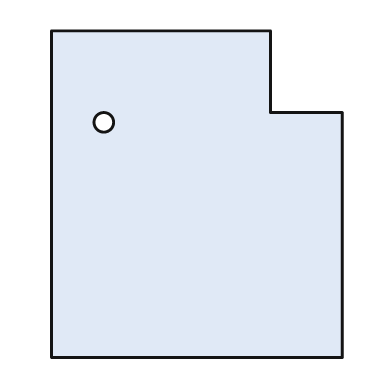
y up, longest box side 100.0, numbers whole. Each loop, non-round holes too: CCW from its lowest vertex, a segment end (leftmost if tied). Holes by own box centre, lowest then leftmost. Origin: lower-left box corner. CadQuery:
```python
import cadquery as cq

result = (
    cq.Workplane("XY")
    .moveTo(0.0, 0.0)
    .lineTo(89.0, 0.0)
    .lineTo(89.0, 75.0)
    .lineTo(67.0, 75.0)
    .lineTo(67.0, 100.0)
    .lineTo(0.0, 100.0)
    .close()
    .moveTo(16.0, 72.0)
    .circle(3.0)
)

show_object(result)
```